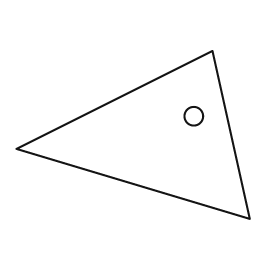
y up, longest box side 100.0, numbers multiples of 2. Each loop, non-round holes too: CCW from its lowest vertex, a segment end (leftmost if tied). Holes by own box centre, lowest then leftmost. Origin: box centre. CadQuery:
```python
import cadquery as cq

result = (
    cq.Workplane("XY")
    .moveTo(50.0, -36.0)
    .lineTo(34.0, 36.0)
    .lineTo(-50.0, -6.0)
    .close()
    .moveTo(26.0, 8.0)
    .circle(4.0)
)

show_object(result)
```